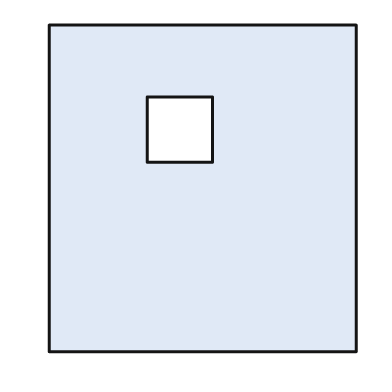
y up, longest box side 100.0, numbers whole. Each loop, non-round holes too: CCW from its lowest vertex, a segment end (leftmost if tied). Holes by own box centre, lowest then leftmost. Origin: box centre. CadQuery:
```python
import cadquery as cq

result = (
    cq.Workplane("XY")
    .moveTo(-47.0, -50.0)
    .lineTo(47.0, -50.0)
    .lineTo(47.0, 50.0)
    .lineTo(-47.0, 50.0)
    .close()
    .moveTo(-17.0, 8.0)
    .lineTo(3.0, 8.0)
    .lineTo(3.0, 28.0)
    .lineTo(-17.0, 28.0)
    .close()
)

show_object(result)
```